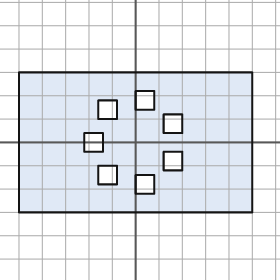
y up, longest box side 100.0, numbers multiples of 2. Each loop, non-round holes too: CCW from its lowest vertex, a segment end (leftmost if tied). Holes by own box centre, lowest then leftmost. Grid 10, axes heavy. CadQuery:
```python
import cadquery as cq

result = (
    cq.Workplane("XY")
    .moveTo(-50.0, -30.0)
    .lineTo(50.0, -30.0)
    .lineTo(50.0, 30.0)
    .lineTo(-50.0, 30.0)
    .close()
    .moveTo(0.0, -22.0)
    .lineTo(8.0, -22.0)
    .lineTo(8.0, -14.0)
    .lineTo(0.0, -14.0)
    .close()
    .moveTo(-16.0, -18.0)
    .lineTo(-8.0, -18.0)
    .lineTo(-8.0, -10.0)
    .lineTo(-16.0, -10.0)
    .close()
    .moveTo(12.0, -12.0)
    .lineTo(20.0, -12.0)
    .lineTo(20.0, -4.0)
    .lineTo(12.0, -4.0)
    .close()
    .moveTo(-22.0, -4.0)
    .lineTo(-14.0, -4.0)
    .lineTo(-14.0, 4.0)
    .lineTo(-22.0, 4.0)
    .close()
    .moveTo(12.0, 4.0)
    .lineTo(20.0, 4.0)
    .lineTo(20.0, 12.0)
    .lineTo(12.0, 12.0)
    .close()
    .moveTo(-16.0, 10.0)
    .lineTo(-8.0, 10.0)
    .lineTo(-8.0, 18.0)
    .lineTo(-16.0, 18.0)
    .close()
    .moveTo(0.0, 14.0)
    .lineTo(8.0, 14.0)
    .lineTo(8.0, 22.0)
    .lineTo(0.0, 22.0)
    .close()
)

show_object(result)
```